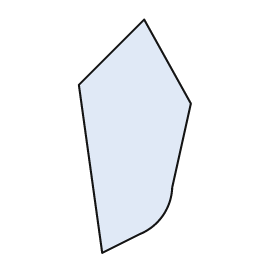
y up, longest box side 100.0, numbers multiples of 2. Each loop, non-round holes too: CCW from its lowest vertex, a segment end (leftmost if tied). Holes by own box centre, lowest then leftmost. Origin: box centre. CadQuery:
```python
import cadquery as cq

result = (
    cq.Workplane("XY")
    .moveTo(-14.0, -50.0)
    .lineTo(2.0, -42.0)
    .threePointArc((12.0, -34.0), (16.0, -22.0))
    .lineTo(24.0, 14.0)
    .lineTo(4.0, 50.0)
    .lineTo(-24.0, 22.0)
    .close()
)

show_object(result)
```